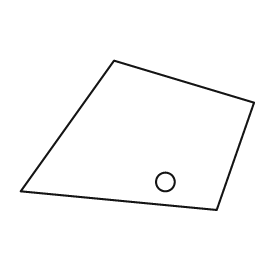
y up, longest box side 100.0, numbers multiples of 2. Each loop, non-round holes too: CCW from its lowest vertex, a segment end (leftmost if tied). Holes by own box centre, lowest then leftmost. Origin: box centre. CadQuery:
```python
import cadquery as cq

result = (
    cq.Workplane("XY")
    .moveTo(34.0, -32.0)
    .lineTo(50.0, 14.0)
    .lineTo(-10.0, 32.0)
    .lineTo(-50.0, -24.0)
    .close()
    .moveTo(12.0, -20.0)
    .circle(4.0)
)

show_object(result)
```